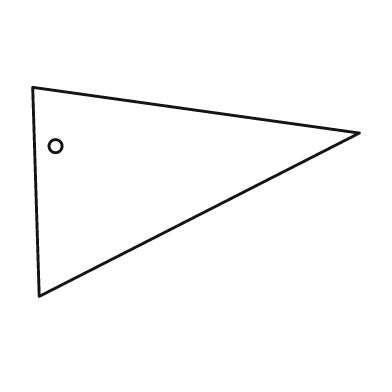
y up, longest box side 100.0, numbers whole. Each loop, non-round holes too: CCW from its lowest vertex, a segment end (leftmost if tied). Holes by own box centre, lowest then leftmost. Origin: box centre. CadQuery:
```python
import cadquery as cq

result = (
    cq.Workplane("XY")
    .moveTo(-48.0, -32.0)
    .lineTo(50.0, 18.0)
    .lineTo(-50.0, 32.0)
    .close()
    .moveTo(-43.0, 14.0)
    .circle(2.0)
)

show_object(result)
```